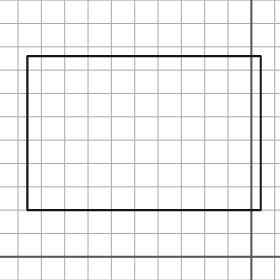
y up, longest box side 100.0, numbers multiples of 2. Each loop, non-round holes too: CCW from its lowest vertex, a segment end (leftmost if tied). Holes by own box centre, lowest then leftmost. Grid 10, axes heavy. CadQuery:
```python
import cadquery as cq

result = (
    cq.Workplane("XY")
    .moveTo(-96.0, 20.0)
    .lineTo(4.0, 20.0)
    .lineTo(4.0, 86.0)
    .lineTo(-96.0, 86.0)
    .close()
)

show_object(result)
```